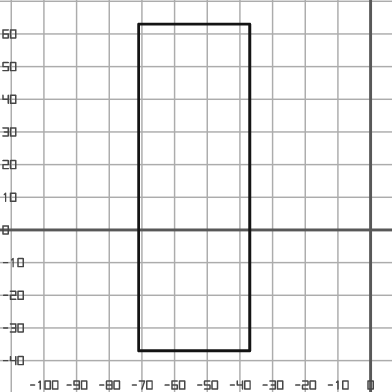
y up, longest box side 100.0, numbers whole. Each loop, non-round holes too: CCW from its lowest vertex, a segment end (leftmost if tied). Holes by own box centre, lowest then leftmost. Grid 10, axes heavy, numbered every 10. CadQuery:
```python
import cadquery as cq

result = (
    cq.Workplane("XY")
    .moveTo(-71.0, -37.0)
    .lineTo(-37.0, -37.0)
    .lineTo(-37.0, 63.0)
    .lineTo(-71.0, 63.0)
    .close()
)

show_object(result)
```